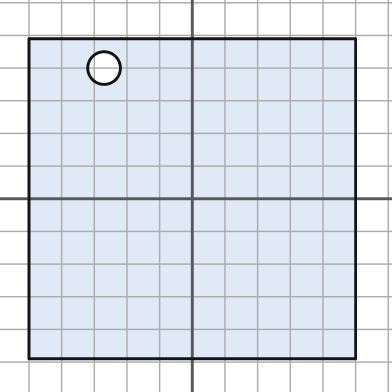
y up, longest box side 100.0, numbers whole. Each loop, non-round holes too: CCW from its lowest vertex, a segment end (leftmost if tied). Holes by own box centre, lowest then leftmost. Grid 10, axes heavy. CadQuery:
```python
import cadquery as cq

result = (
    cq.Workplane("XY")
    .moveTo(-50.0, -49.0)
    .lineTo(50.0, -49.0)
    .lineTo(50.0, 49.0)
    .lineTo(-50.0, 49.0)
    .close()
    .moveTo(-27.0, 40.0)
    .circle(5.0)
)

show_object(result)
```